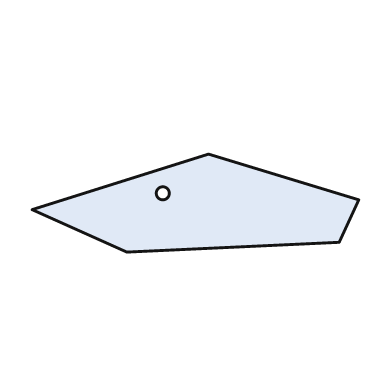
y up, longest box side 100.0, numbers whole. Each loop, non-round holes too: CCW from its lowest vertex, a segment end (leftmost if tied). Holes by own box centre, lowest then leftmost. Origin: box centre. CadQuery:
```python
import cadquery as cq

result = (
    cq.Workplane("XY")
    .moveTo(-21.0, -15.0)
    .lineTo(44.0, -12.0)
    .lineTo(50.0, 1.0)
    .lineTo(4.0, 15.0)
    .lineTo(-50.0, -2.0)
    .close()
    .moveTo(-10.0, 3.0)
    .circle(2.0)
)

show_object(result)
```